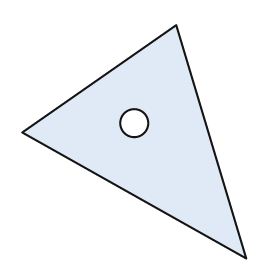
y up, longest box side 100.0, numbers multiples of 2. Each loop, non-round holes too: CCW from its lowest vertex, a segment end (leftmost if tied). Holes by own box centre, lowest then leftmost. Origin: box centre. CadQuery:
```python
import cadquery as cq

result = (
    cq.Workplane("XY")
    .moveTo(48.0, -50.0)
    .lineTo(18.0, 50.0)
    .lineTo(-48.0, 4.0)
    .close()
    .moveTo(0.0, 8.0)
    .circle(6.0)
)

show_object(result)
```